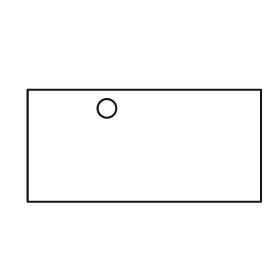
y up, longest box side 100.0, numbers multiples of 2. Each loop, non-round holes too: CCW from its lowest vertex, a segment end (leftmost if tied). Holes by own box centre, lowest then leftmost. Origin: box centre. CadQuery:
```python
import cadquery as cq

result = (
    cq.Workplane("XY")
    .moveTo(-50.0, -24.0)
    .lineTo(50.0, -24.0)
    .lineTo(50.0, 24.0)
    .lineTo(-50.0, 24.0)
    .close()
    .moveTo(-16.0, 16.0)
    .circle(4.0)
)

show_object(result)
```